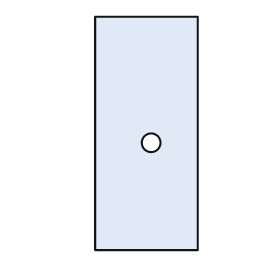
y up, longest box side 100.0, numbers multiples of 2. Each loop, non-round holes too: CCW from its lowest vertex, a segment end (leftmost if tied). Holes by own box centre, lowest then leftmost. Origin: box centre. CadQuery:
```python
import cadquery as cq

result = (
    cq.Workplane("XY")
    .moveTo(-22.0, -50.0)
    .lineTo(22.0, -50.0)
    .lineTo(22.0, 50.0)
    .lineTo(-22.0, 50.0)
    .close()
    .moveTo(2.0, -4.0)
    .circle(4.0)
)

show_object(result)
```